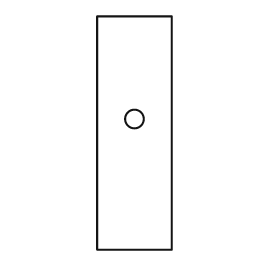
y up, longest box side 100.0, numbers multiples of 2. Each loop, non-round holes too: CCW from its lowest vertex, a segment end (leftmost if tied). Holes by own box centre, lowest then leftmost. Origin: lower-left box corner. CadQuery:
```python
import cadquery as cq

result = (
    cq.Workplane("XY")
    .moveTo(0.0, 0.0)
    .lineTo(32.0, 0.0)
    .lineTo(32.0, 100.0)
    .lineTo(0.0, 100.0)
    .close()
    .moveTo(16.0, 56.0)
    .circle(4.0)
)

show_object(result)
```